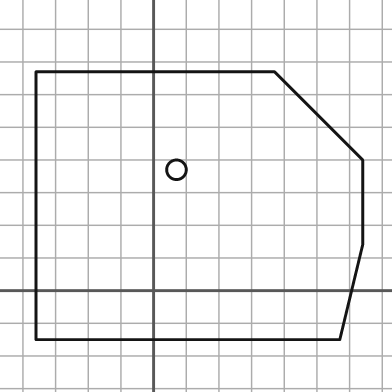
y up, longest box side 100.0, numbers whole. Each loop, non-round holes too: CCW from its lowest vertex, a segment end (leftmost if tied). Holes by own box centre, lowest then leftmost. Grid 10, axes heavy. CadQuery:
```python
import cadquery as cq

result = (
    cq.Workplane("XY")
    .moveTo(-36.0, -15.0)
    .lineTo(57.0, -15.0)
    .lineTo(64.0, 14.0)
    .lineTo(64.0, 40.0)
    .lineTo(37.0, 67.0)
    .lineTo(-36.0, 67.0)
    .close()
    .moveTo(7.0, 37.0)
    .circle(3.0)
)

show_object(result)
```